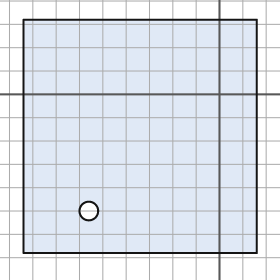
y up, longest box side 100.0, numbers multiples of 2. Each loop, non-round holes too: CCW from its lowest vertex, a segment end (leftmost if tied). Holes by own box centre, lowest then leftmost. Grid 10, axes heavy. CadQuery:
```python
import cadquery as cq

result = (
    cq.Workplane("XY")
    .moveTo(-84.0, -68.0)
    .lineTo(16.0, -68.0)
    .lineTo(16.0, 32.0)
    .lineTo(-84.0, 32.0)
    .close()
    .moveTo(-56.0, -50.0)
    .circle(4.0)
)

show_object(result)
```